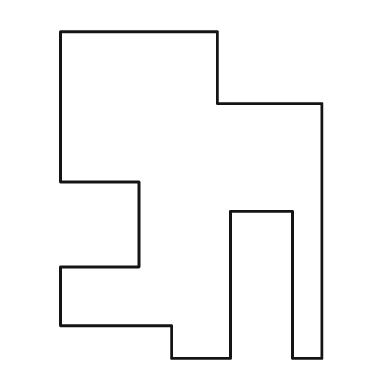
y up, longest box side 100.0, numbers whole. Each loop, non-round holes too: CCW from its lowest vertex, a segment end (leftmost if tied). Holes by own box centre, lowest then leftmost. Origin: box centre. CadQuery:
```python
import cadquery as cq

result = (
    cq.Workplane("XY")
    .moveTo(-6.0, -50.0)
    .lineTo(12.0, -50.0)
    .lineTo(12.0, -5.0)
    .lineTo(31.0, -5.0)
    .lineTo(31.0, -50.0)
    .lineTo(40.0, -50.0)
    .lineTo(40.0, 28.0)
    .lineTo(8.0, 28.0)
    .lineTo(8.0, 50.0)
    .lineTo(-40.0, 50.0)
    .lineTo(-40.0, 4.0)
    .lineTo(-16.0, 4.0)
    .lineTo(-16.0, -22.0)
    .lineTo(-40.0, -22.0)
    .lineTo(-40.0, -40.0)
    .lineTo(-6.0, -40.0)
    .close()
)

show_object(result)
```